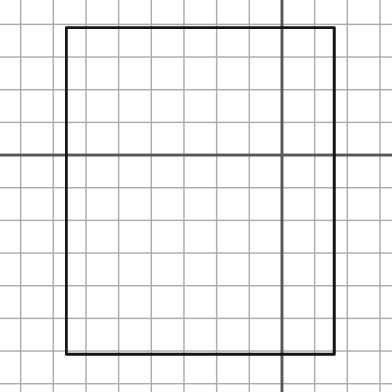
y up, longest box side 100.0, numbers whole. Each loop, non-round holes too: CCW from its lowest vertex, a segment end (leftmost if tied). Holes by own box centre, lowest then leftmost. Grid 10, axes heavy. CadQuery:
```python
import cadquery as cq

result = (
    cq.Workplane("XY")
    .moveTo(-66.0, -61.0)
    .lineTo(16.0, -61.0)
    .lineTo(16.0, 39.0)
    .lineTo(-66.0, 39.0)
    .close()
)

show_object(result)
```